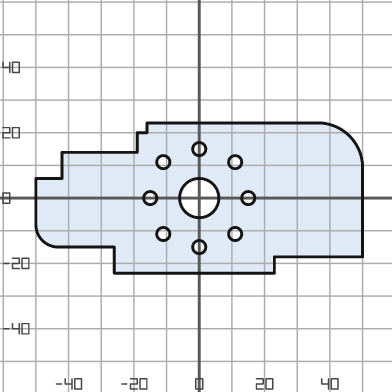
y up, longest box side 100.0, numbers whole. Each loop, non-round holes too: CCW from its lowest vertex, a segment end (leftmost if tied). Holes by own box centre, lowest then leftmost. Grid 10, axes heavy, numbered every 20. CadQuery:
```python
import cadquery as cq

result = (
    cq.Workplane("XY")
    .moveTo(-26.0, -23.0)
    .lineTo(23.0, -23.0)
    .lineTo(23.0, -18.0)
    .lineTo(50.0, -18.0)
    .lineTo(50.0, 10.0)
    .threePointArc((46.0, 19.0), (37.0, 23.0))
    .lineTo(-16.0, 23.0)
    .lineTo(-16.0, 20.0)
    .lineTo(-19.0, 20.0)
    .lineTo(-19.0, 14.0)
    .lineTo(-42.0, 14.0)
    .lineTo(-42.0, 6.0)
    .lineTo(-50.0, 6.0)
    .lineTo(-50.0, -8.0)
    .threePointArc((-48.0, -13.0), (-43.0, -15.0))
    .lineTo(-26.0, -15.0)
    .close()
    .moveTo(0.0, -15.0)
    .circle(2.0)
    .moveTo(-11.0, -11.0)
    .circle(2.0)
    .moveTo(11.0, -11.0)
    .circle(2.0)
    .moveTo(-15.0, 0.0)
    .circle(2.0)
    .moveTo(0.0, 0.0)
    .circle(6.0)
    .moveTo(15.0, 0.0)
    .circle(2.0)
    .moveTo(-11.0, 11.0)
    .circle(2.0)
    .moveTo(11.0, 11.0)
    .circle(2.0)
    .moveTo(0.0, 15.0)
    .circle(2.0)
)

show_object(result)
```